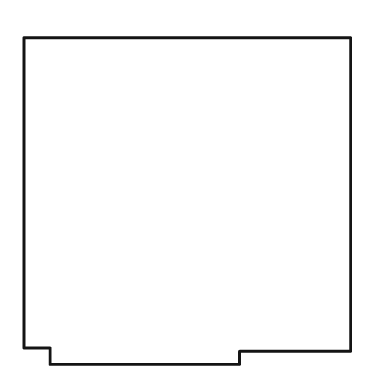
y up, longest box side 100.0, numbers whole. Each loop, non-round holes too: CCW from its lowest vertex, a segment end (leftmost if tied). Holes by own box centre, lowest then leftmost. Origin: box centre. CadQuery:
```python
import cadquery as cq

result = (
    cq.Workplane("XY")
    .moveTo(-42.0, -50.0)
    .lineTo(16.0, -50.0)
    .lineTo(16.0, -46.0)
    .lineTo(50.0, -46.0)
    .lineTo(50.0, 50.0)
    .lineTo(-50.0, 50.0)
    .lineTo(-50.0, -45.0)
    .lineTo(-42.0, -45.0)
    .close()
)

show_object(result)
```